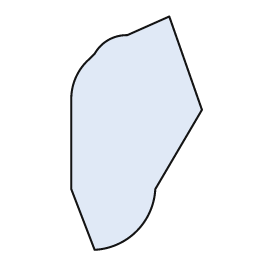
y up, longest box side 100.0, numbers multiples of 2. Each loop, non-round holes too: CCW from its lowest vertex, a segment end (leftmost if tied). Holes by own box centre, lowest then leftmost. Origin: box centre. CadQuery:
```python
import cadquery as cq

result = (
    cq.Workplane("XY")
    .moveTo(-18.0, -50.0)
    .threePointArc((0.0, -42.0), (8.0, -24.0))
    .lineTo(28.0, 10.0)
    .lineTo(14.0, 50.0)
    .lineTo(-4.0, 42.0)
    .threePointArc((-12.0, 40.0), (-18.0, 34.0))
    .lineTo(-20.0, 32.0)
    .threePointArc((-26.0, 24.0), (-28.0, 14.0))
    .lineTo(-28.0, -24.0)
    .close()
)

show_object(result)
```